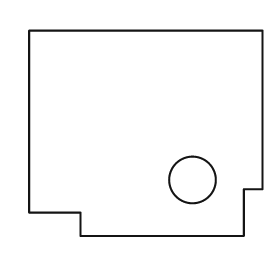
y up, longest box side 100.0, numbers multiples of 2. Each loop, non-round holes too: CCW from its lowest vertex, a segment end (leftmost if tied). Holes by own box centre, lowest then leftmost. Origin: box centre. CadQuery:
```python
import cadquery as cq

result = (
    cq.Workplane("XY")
    .moveTo(-28.0, -44.0)
    .lineTo(42.0, -44.0)
    .lineTo(42.0, -24.0)
    .lineTo(50.0, -24.0)
    .lineTo(50.0, 44.0)
    .lineTo(-50.0, 44.0)
    .lineTo(-50.0, -34.0)
    .lineTo(-28.0, -34.0)
    .close()
    .moveTo(20.0, -20.0)
    .circle(10.0)
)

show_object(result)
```